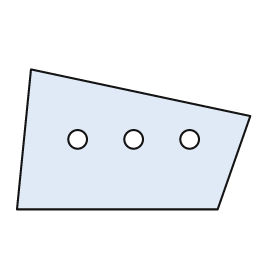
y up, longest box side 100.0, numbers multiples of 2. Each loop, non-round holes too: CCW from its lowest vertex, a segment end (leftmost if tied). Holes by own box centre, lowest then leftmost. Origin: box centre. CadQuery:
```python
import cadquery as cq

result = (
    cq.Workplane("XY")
    .moveTo(-50.0, -30.0)
    .lineTo(36.0, -30.0)
    .lineTo(50.0, 10.0)
    .lineTo(-44.0, 30.0)
    .close()
    .moveTo(-24.0, 0.0)
    .circle(4.0)
    .moveTo(0.0, 0.0)
    .circle(4.0)
    .moveTo(24.0, 0.0)
    .circle(4.0)
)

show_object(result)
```